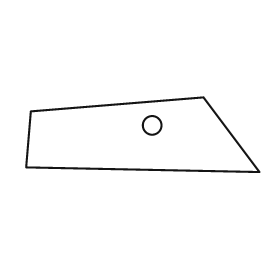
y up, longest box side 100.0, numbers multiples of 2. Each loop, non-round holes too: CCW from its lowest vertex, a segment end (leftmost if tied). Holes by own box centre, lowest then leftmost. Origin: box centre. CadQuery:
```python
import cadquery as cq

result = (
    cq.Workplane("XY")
    .moveTo(50.0, -16.0)
    .lineTo(26.0, 16.0)
    .lineTo(-48.0, 10.0)
    .lineTo(-50.0, -14.0)
    .close()
    .moveTo(4.0, 4.0)
    .circle(4.0)
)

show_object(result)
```